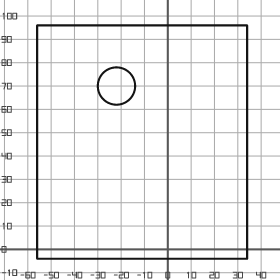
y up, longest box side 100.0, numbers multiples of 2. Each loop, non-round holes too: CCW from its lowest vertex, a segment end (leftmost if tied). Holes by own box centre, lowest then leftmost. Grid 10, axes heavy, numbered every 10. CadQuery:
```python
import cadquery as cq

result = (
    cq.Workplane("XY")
    .moveTo(-56.0, -4.0)
    .lineTo(34.0, -4.0)
    .lineTo(34.0, 96.0)
    .lineTo(-56.0, 96.0)
    .close()
    .moveTo(-22.0, 70.0)
    .circle(8.0)
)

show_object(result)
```